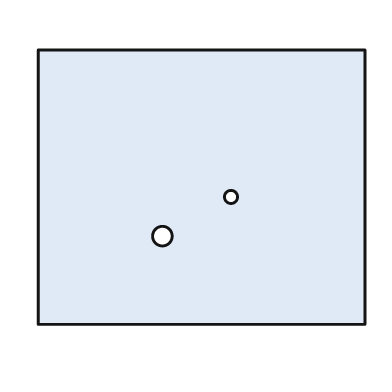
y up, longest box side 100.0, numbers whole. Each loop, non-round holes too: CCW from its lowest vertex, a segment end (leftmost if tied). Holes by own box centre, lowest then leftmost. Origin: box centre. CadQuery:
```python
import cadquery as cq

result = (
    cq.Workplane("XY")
    .moveTo(-50.0, -42.0)
    .lineTo(50.0, -42.0)
    .lineTo(50.0, 42.0)
    .lineTo(-50.0, 42.0)
    .close()
    .moveTo(-12.0, -15.0)
    .circle(3.0)
    .moveTo(9.0, -3.0)
    .circle(2.0)
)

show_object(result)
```